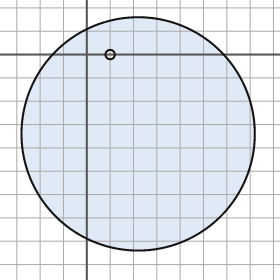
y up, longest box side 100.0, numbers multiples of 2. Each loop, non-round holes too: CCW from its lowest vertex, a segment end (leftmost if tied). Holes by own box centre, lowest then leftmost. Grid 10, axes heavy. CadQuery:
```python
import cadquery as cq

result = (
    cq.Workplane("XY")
    .moveTo(22.0, -34.0)
    .circle(50.0)
    .moveTo(10.0, 0.0)
    .circle(2.0)
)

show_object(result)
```